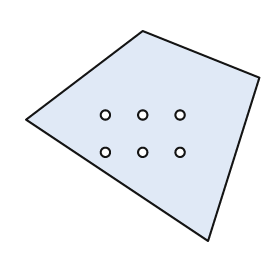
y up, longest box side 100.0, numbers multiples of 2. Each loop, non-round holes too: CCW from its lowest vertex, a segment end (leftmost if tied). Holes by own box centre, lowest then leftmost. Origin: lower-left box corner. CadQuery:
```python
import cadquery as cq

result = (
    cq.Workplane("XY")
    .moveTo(78.0, 0.0)
    .lineTo(100.0, 70.0)
    .lineTo(50.0, 90.0)
    .lineTo(0.0, 52.0)
    .close()
    .moveTo(34.0, 38.0)
    .circle(2.0)
    .moveTo(50.0, 38.0)
    .circle(2.0)
    .moveTo(66.0, 38.0)
    .circle(2.0)
    .moveTo(34.0, 54.0)
    .circle(2.0)
    .moveTo(50.0, 54.0)
    .circle(2.0)
    .moveTo(66.0, 54.0)
    .circle(2.0)
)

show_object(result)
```